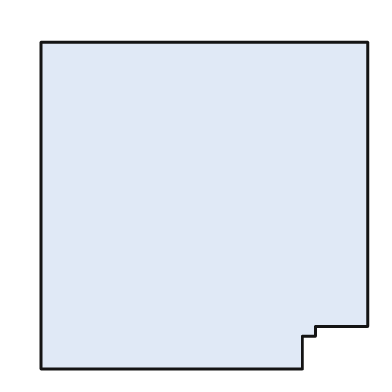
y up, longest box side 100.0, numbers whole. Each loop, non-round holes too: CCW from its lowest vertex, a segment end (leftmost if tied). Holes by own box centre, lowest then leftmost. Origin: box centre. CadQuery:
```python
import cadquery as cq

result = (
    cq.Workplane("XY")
    .moveTo(-50.0, -50.0)
    .lineTo(30.0, -50.0)
    .lineTo(30.0, -40.0)
    .lineTo(34.0, -40.0)
    .lineTo(34.0, -37.0)
    .lineTo(50.0, -37.0)
    .lineTo(50.0, 50.0)
    .lineTo(-50.0, 50.0)
    .close()
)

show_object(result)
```